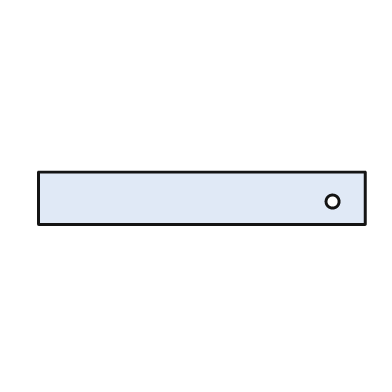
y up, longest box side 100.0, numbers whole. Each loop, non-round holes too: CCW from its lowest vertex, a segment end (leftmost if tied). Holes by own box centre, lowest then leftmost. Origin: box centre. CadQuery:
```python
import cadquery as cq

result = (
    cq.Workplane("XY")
    .moveTo(-50.0, -8.0)
    .lineTo(50.0, -8.0)
    .lineTo(50.0, 8.0)
    .lineTo(-50.0, 8.0)
    .close()
    .moveTo(40.0, -1.0)
    .circle(2.0)
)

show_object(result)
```